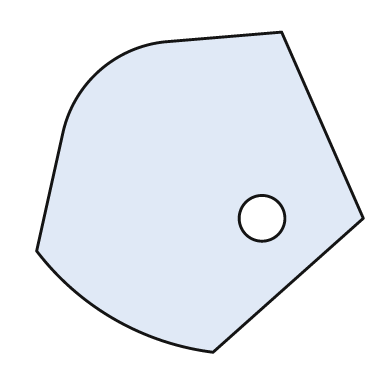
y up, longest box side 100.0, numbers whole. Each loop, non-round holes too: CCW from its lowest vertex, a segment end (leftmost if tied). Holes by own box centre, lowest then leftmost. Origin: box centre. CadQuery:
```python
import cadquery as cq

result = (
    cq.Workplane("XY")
    .moveTo(4.0, -49.0)
    .lineTo(50.0, -8.0)
    .lineTo(25.0, 49.0)
    .lineTo(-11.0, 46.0)
    .threePointArc((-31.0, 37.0), (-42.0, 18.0))
    .lineTo(-50.0, -18.0)
    .threePointArc((-26.0, -39.0), (4.0, -49.0))
    .close()
    .moveTo(19.0, -8.0)
    .circle(7.0)
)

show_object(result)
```